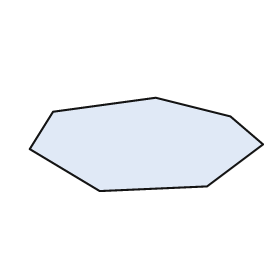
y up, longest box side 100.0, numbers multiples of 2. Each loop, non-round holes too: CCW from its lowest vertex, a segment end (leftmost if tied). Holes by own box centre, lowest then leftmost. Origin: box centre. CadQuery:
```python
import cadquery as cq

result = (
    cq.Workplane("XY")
    .moveTo(-20.0, -20.0)
    .lineTo(26.0, -18.0)
    .lineTo(50.0, 0.0)
    .lineTo(36.0, 12.0)
    .lineTo(4.0, 20.0)
    .lineTo(-40.0, 14.0)
    .lineTo(-50.0, -2.0)
    .close()
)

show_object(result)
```